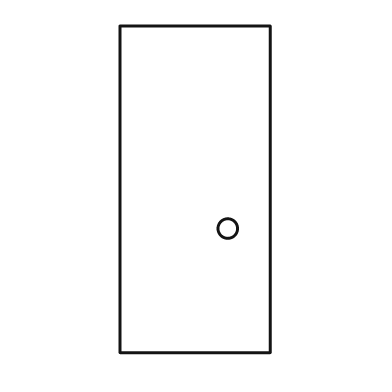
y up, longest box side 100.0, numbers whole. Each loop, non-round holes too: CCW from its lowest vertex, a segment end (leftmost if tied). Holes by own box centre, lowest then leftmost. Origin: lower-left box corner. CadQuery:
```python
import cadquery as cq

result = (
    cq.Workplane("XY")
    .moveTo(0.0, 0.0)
    .lineTo(46.0, 0.0)
    .lineTo(46.0, 100.0)
    .lineTo(0.0, 100.0)
    .close()
    .moveTo(33.0, 38.0)
    .circle(3.0)
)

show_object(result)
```